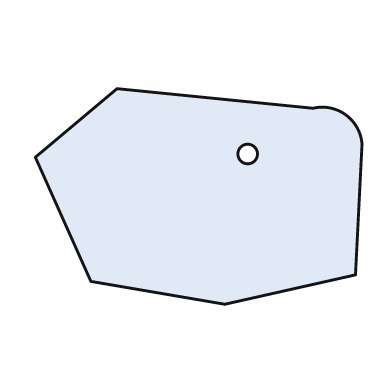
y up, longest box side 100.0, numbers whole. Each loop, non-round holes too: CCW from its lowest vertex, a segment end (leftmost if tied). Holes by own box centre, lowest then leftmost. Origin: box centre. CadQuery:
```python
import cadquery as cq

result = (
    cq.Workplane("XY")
    .moveTo(8.0, -33.0)
    .lineTo(48.0, -24.0)
    .lineTo(50.0, 16.0)
    .threePointArc((45.0, 25.0), (35.0, 27.0))
    .lineTo(-25.0, 33.0)
    .lineTo(-50.0, 12.0)
    .lineTo(-33.0, -26.0)
    .close()
    .moveTo(15.0, 13.0)
    .circle(3.0)
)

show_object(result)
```